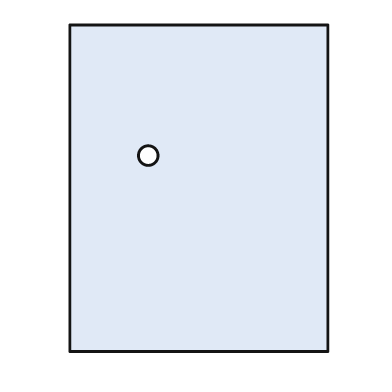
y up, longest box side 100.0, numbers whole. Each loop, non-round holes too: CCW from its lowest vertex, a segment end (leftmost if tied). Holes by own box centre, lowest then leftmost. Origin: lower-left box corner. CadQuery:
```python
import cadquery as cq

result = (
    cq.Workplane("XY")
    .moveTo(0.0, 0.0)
    .lineTo(79.0, 0.0)
    .lineTo(79.0, 100.0)
    .lineTo(0.0, 100.0)
    .close()
    .moveTo(24.0, 60.0)
    .circle(3.0)
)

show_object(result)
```